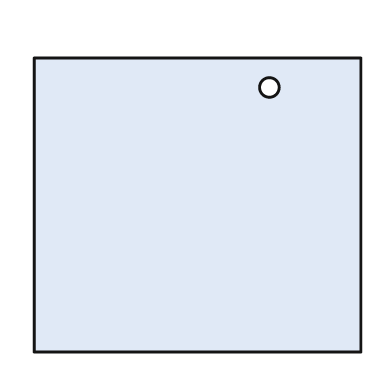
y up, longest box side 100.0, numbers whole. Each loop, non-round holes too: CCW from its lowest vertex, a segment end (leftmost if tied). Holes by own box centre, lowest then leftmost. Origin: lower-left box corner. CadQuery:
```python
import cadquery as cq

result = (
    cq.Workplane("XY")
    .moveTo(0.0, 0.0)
    .lineTo(100.0, 0.0)
    .lineTo(100.0, 90.0)
    .lineTo(0.0, 90.0)
    .close()
    .moveTo(72.0, 81.0)
    .circle(3.0)
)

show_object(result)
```